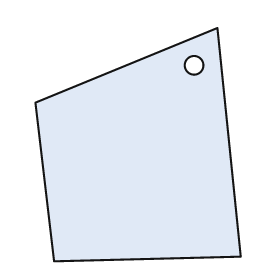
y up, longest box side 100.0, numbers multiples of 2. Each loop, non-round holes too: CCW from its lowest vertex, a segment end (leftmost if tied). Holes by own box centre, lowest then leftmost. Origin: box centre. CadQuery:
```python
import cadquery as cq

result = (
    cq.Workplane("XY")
    .moveTo(-36.0, -50.0)
    .lineTo(44.0, -48.0)
    .lineTo(34.0, 50.0)
    .lineTo(-44.0, 18.0)
    .close()
    .moveTo(24.0, 34.0)
    .circle(4.0)
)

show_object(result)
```